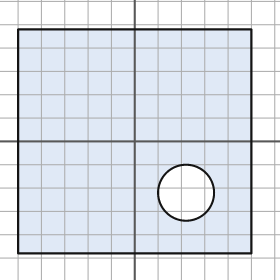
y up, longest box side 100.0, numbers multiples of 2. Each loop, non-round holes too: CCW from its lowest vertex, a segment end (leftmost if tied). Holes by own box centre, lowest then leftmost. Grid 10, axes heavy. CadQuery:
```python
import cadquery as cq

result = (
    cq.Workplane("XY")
    .moveTo(-50.0, -48.0)
    .lineTo(50.0, -48.0)
    .lineTo(50.0, 48.0)
    .lineTo(-50.0, 48.0)
    .close()
    .moveTo(22.0, -22.0)
    .circle(12.0)
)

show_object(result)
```